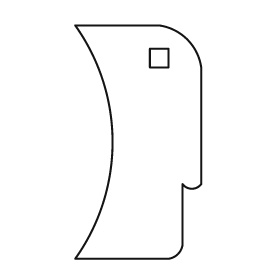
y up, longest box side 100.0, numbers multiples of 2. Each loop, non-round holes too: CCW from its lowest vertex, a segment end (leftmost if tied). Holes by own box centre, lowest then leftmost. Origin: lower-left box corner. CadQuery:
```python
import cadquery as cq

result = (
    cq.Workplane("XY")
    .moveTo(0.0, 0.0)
    .lineTo(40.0, 0.0)
    .threePointArc((44.0, 2.0), (46.0, 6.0))
    .lineTo(46.0, 32.0)
    .threePointArc((50.0, 30.0), (54.0, 32.0))
    .lineTo(54.0, 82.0)
    .threePointArc((48.0, 94.0), (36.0, 100.0))
    .lineTo(0.0, 100.0)
    .threePointArc((16.0, 50.0), (0.0, 0.0))
    .close()
    .moveTo(32.0, 82.0)
    .lineTo(40.0, 82.0)
    .lineTo(40.0, 90.0)
    .lineTo(32.0, 90.0)
    .close()
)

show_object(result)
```